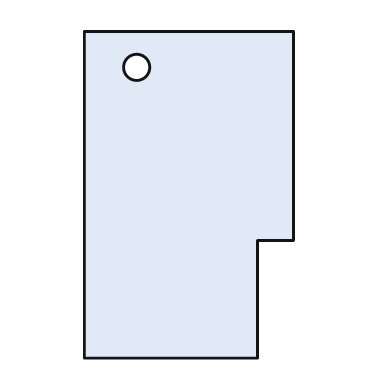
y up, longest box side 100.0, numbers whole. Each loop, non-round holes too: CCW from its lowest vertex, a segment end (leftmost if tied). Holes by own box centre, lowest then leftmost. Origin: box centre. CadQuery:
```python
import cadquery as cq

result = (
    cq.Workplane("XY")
    .moveTo(-32.0, -50.0)
    .lineTo(21.0, -50.0)
    .lineTo(21.0, -14.0)
    .lineTo(32.0, -14.0)
    .lineTo(32.0, 50.0)
    .lineTo(-32.0, 50.0)
    .close()
    .moveTo(-16.0, 39.0)
    .circle(4.0)
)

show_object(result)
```